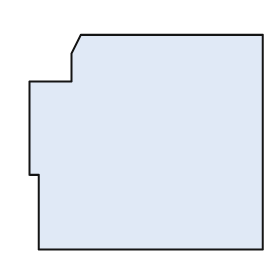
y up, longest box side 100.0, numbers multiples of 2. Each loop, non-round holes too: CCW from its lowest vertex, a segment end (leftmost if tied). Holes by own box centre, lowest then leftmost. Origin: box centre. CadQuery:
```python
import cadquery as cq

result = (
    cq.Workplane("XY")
    .moveTo(-46.0, -46.0)
    .lineTo(50.0, -46.0)
    .lineTo(50.0, 46.0)
    .lineTo(-28.0, 46.0)
    .lineTo(-32.0, 38.0)
    .lineTo(-32.0, 26.0)
    .lineTo(-50.0, 26.0)
    .lineTo(-50.0, -14.0)
    .lineTo(-46.0, -14.0)
    .close()
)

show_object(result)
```